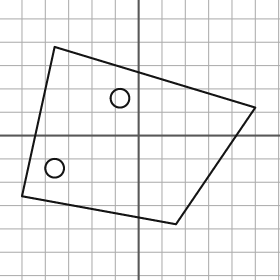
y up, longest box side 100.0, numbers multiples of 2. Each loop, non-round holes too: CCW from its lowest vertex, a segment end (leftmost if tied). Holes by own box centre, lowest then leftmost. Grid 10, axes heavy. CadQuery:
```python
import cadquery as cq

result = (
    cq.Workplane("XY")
    .moveTo(16.0, -38.0)
    .lineTo(50.0, 12.0)
    .lineTo(-36.0, 38.0)
    .lineTo(-50.0, -26.0)
    .close()
    .moveTo(-36.0, -14.0)
    .circle(4.0)
    .moveTo(-8.0, 16.0)
    .circle(4.0)
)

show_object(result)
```